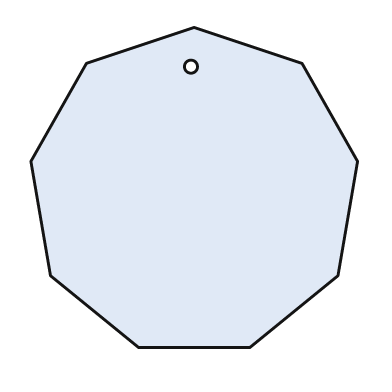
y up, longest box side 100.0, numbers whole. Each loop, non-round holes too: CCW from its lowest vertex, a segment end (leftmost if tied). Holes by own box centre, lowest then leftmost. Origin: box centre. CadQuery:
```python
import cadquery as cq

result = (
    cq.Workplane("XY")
    .moveTo(-17.0, -49.0)
    .lineTo(17.0, -49.0)
    .lineTo(44.0, -27.0)
    .lineTo(50.0, 8.0)
    .lineTo(33.0, 38.0)
    .lineTo(0.0, 49.0)
    .lineTo(-33.0, 38.0)
    .lineTo(-50.0, 8.0)
    .lineTo(-44.0, -27.0)
    .close()
    .moveTo(-1.0, 37.0)
    .circle(2.0)
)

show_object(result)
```